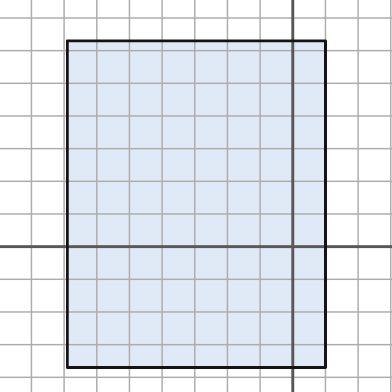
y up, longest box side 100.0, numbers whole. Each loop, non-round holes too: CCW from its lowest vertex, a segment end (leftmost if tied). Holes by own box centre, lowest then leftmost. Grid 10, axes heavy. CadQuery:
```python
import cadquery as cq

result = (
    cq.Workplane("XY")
    .moveTo(-69.0, -37.0)
    .lineTo(10.0, -37.0)
    .lineTo(10.0, 63.0)
    .lineTo(-69.0, 63.0)
    .close()
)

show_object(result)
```